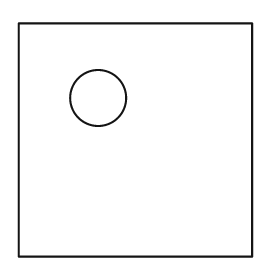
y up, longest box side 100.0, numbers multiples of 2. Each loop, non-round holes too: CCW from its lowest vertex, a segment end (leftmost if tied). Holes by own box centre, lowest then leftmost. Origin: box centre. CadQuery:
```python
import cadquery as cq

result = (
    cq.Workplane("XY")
    .moveTo(-50.0, -50.0)
    .lineTo(50.0, -50.0)
    .lineTo(50.0, 50.0)
    .lineTo(-50.0, 50.0)
    .close()
    .moveTo(-16.0, 18.0)
    .circle(12.0)
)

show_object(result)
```